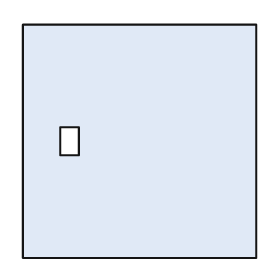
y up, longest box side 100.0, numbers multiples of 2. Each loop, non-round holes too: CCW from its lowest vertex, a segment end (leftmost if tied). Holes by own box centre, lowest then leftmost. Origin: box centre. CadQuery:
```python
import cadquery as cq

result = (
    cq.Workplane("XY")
    .moveTo(-50.0, -50.0)
    .lineTo(50.0, -50.0)
    .lineTo(50.0, 50.0)
    .lineTo(-50.0, 50.0)
    .close()
    .moveTo(-34.0, -6.0)
    .lineTo(-26.0, -6.0)
    .lineTo(-26.0, 6.0)
    .lineTo(-34.0, 6.0)
    .close()
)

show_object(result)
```